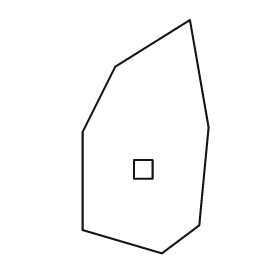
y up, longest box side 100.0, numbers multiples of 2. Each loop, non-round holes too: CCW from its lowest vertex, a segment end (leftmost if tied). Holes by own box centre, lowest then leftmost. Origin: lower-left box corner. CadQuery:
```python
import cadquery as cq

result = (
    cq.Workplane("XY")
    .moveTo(34.0, 0.0)
    .lineTo(50.0, 12.0)
    .lineTo(54.0, 54.0)
    .lineTo(46.0, 100.0)
    .lineTo(14.0, 80.0)
    .lineTo(0.0, 52.0)
    .lineTo(0.0, 10.0)
    .close()
    .moveTo(22.0, 32.0)
    .lineTo(30.0, 32.0)
    .lineTo(30.0, 40.0)
    .lineTo(22.0, 40.0)
    .close()
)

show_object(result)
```